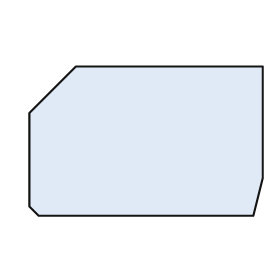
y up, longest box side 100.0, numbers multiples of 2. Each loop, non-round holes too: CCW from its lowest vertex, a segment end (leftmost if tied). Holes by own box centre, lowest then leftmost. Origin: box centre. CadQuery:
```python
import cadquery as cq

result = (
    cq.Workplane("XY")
    .moveTo(-46.0, -32.0)
    .lineTo(46.0, -32.0)
    .lineTo(50.0, -16.0)
    .lineTo(50.0, 32.0)
    .lineTo(-30.0, 32.0)
    .lineTo(-50.0, 12.0)
    .lineTo(-50.0, -28.0)
    .close()
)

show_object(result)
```